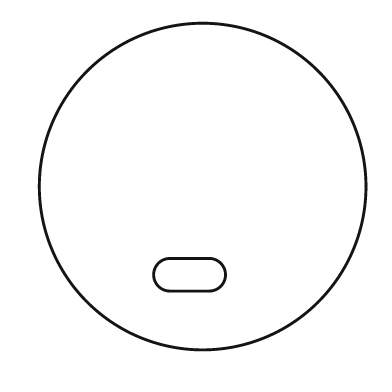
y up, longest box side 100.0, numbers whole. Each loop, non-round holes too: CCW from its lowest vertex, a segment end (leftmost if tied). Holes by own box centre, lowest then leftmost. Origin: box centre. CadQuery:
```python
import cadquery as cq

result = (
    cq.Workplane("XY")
    .moveTo(0.0, 0.0)
    .circle(50.0)
    .moveTo(-10.0, -32.0)
    .lineTo(2.0, -32.0)
    .threePointArc((7.0, -27.0), (2.0, -22.0))
    .lineTo(-10.0, -22.0)
    .threePointArc((-15.0, -27.0), (-10.0, -32.0))
    .close()
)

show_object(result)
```